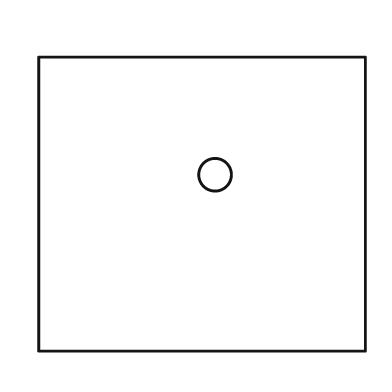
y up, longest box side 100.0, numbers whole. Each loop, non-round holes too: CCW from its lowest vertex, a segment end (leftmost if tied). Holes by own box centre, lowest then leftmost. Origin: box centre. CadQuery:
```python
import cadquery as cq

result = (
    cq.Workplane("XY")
    .moveTo(-50.0, -45.0)
    .lineTo(50.0, -45.0)
    .lineTo(50.0, 45.0)
    .lineTo(-50.0, 45.0)
    .close()
    .moveTo(4.0, 9.0)
    .circle(5.0)
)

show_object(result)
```